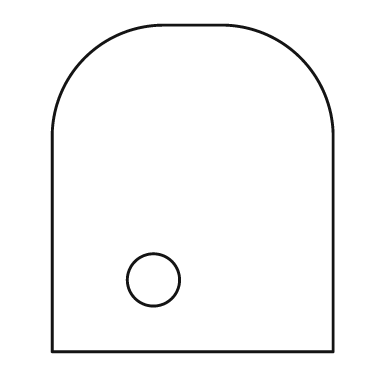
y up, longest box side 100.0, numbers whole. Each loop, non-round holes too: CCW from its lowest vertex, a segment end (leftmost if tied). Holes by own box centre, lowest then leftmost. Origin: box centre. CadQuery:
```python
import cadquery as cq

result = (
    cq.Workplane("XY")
    .moveTo(-43.0, -50.0)
    .lineTo(43.0, -50.0)
    .lineTo(43.0, 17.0)
    .threePointArc((33.0, 40.0), (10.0, 50.0))
    .lineTo(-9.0, 50.0)
    .threePointArc((-33.0, 40.0), (-43.0, 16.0))
    .close()
    .moveTo(-12.0, -28.0)
    .circle(8.0)
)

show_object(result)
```